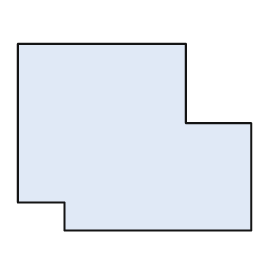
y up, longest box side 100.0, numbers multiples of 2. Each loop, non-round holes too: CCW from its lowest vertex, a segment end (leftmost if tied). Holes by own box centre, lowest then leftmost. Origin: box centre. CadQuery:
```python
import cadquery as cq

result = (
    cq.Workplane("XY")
    .moveTo(-30.0, -40.0)
    .lineTo(50.0, -40.0)
    .lineTo(50.0, 6.0)
    .lineTo(22.0, 6.0)
    .lineTo(22.0, 40.0)
    .lineTo(-50.0, 40.0)
    .lineTo(-50.0, -28.0)
    .lineTo(-30.0, -28.0)
    .close()
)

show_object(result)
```